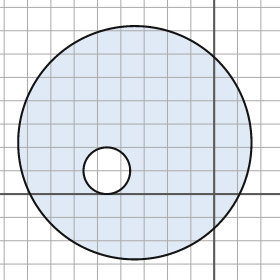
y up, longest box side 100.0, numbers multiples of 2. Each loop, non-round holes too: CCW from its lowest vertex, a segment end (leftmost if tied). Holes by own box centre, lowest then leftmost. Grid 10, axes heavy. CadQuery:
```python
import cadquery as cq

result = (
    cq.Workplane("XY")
    .moveTo(-34.0, 22.0)
    .circle(50.0)
    .moveTo(-46.0, 10.0)
    .circle(10.0)
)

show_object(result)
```